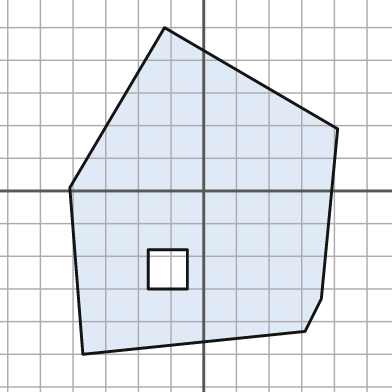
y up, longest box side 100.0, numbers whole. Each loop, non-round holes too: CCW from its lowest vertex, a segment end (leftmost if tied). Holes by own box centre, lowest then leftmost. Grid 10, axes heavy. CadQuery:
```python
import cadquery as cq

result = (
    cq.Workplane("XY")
    .moveTo(-37.0, -50.0)
    .lineTo(31.0, -43.0)
    .lineTo(36.0, -33.0)
    .lineTo(41.0, 19.0)
    .lineTo(-12.0, 50.0)
    .lineTo(-41.0, 1.0)
    .close()
    .moveTo(-17.0, -30.0)
    .lineTo(-5.0, -30.0)
    .lineTo(-5.0, -18.0)
    .lineTo(-17.0, -18.0)
    .close()
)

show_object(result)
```